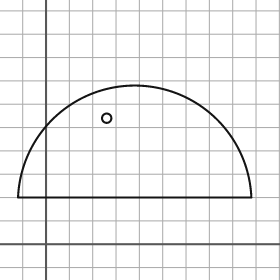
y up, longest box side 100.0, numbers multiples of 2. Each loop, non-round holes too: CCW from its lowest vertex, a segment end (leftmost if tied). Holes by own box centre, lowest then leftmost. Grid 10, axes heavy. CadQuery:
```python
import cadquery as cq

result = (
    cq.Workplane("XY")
    .moveTo(-12.0, 20.0)
    .lineTo(88.0, 20.0)
    .threePointArc((38.0, 68.0), (-12.0, 20.0))
    .close()
    .moveTo(26.0, 54.0)
    .circle(2.0)
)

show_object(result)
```